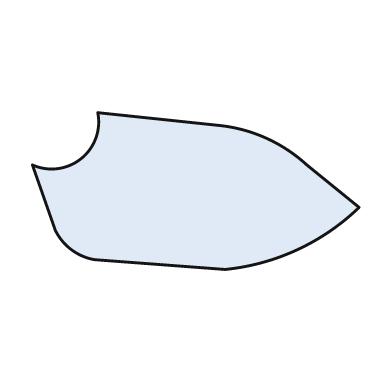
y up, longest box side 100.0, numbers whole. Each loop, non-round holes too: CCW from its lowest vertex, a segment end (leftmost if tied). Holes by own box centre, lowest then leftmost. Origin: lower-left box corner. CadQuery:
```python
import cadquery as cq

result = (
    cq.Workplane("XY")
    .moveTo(59.0, 0.0)
    .threePointArc((81.0, 6.0), (100.0, 19.0))
    .lineTo(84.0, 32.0)
    .threePointArc((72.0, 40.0), (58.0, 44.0))
    .lineTo(20.0, 48.0)
    .threePointArc((15.0, 34.0), (0.0, 32.0))
    .lineTo(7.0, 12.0)
    .threePointArc((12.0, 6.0), (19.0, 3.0))
    .close()
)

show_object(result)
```